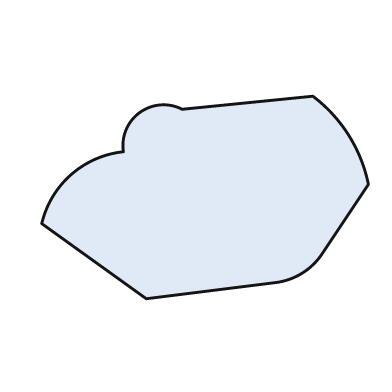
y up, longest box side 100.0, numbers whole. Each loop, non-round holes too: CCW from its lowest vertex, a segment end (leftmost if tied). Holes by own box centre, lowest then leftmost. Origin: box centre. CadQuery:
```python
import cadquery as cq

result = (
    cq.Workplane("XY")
    .moveTo(-18.0, -31.0)
    .lineTo(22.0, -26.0)
    .threePointArc((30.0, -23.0), (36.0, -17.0))
    .lineTo(50.0, 4.0)
    .threePointArc((44.0, 19.0), (33.0, 31.0))
    .lineTo(-7.0, 27.0)
    .threePointArc((-20.0, 26.0), (-25.0, 14.0))
    .threePointArc((-41.0, 7.0), (-50.0, -8.0))
    .close()
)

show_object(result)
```